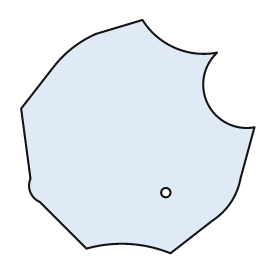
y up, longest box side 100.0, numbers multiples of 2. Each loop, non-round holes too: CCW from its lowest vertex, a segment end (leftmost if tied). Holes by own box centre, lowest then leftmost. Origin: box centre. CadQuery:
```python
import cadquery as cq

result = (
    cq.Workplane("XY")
    .moveTo(14.0, -50.0)
    .lineTo(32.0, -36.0)
    .threePointArc((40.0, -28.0), (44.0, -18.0))
    .lineTo(50.0, 4.0)
    .threePointArc((30.0, 14.0), (34.0, 36.0))
    .threePointArc((16.0, 38.0), (2.0, 50.0))
    .lineTo(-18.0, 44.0)
    .threePointArc((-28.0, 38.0), (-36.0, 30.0))
    .lineTo(-50.0, 12.0)
    .lineTo(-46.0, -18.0)
    .threePointArc((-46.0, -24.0), (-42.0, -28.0))
    .lineTo(-22.0, -48.0)
    .threePointArc((-4.0, -46.0), (14.0, -50.0))
    .close()
    .moveTo(12.0, -24.0)
    .circle(2.0)
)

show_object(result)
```